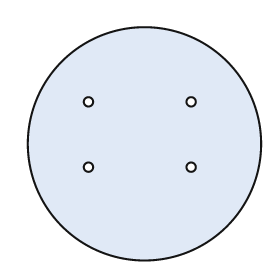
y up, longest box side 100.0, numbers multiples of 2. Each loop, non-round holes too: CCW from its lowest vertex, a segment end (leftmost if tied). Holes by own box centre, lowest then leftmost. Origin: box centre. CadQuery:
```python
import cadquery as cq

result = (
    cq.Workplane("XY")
    .moveTo(0.0, 0.0)
    .circle(50.0)
    .moveTo(-24.0, -10.0)
    .circle(2.0)
    .moveTo(20.0, -10.0)
    .circle(2.0)
    .moveTo(-24.0, 18.0)
    .circle(2.0)
    .moveTo(20.0, 18.0)
    .circle(2.0)
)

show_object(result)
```